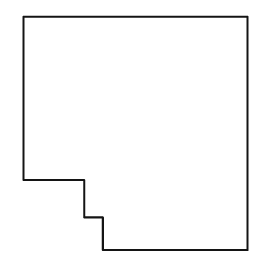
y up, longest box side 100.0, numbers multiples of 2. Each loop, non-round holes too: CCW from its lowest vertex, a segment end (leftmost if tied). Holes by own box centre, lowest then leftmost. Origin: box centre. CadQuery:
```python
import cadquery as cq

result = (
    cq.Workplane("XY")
    .moveTo(-14.0, -50.0)
    .lineTo(48.0, -50.0)
    .lineTo(48.0, 50.0)
    .lineTo(-48.0, 50.0)
    .lineTo(-48.0, -20.0)
    .lineTo(-22.0, -20.0)
    .lineTo(-22.0, -36.0)
    .lineTo(-14.0, -36.0)
    .close()
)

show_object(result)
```